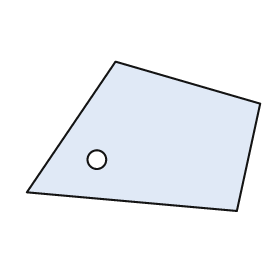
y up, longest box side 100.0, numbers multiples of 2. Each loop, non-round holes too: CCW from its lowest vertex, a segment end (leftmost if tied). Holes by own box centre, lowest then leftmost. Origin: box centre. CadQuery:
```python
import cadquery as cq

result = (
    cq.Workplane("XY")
    .moveTo(40.0, -32.0)
    .lineTo(50.0, 14.0)
    .lineTo(-12.0, 32.0)
    .lineTo(-50.0, -24.0)
    .close()
    .moveTo(-20.0, -10.0)
    .circle(4.0)
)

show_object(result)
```